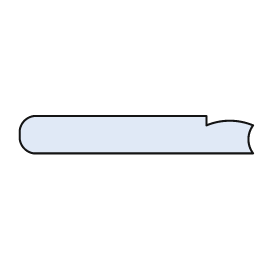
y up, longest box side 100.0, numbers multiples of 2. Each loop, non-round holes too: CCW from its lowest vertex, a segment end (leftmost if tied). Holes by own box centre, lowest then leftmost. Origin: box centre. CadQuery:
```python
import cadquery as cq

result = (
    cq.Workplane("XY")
    .moveTo(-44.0, -8.0)
    .lineTo(50.0, -8.0)
    .threePointArc((48.0, -2.0), (50.0, 4.0))
    .threePointArc((40.0, 6.0), (30.0, 4.0))
    .lineTo(30.0, 8.0)
    .lineTo(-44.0, 8.0)
    .threePointArc((-48.0, 6.0), (-50.0, 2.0))
    .lineTo(-50.0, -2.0)
    .threePointArc((-48.0, -6.0), (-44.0, -8.0))
    .close()
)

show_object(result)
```